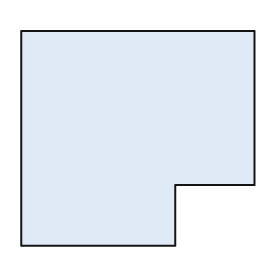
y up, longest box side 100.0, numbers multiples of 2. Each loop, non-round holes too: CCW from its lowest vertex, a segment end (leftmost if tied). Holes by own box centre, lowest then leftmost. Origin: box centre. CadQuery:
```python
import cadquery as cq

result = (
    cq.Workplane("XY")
    .moveTo(-50.0, -46.0)
    .lineTo(16.0, -46.0)
    .lineTo(16.0, -20.0)
    .lineTo(50.0, -20.0)
    .lineTo(50.0, 46.0)
    .lineTo(-50.0, 46.0)
    .close()
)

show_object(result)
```